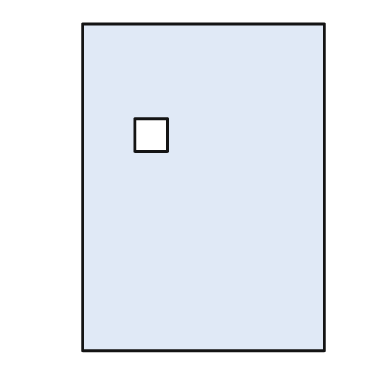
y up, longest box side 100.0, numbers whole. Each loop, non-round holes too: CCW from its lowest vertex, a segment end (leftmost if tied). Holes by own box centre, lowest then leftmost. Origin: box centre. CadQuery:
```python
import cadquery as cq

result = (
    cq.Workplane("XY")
    .moveTo(-37.0, -50.0)
    .lineTo(37.0, -50.0)
    .lineTo(37.0, 50.0)
    .lineTo(-37.0, 50.0)
    .close()
    .moveTo(-21.0, 11.0)
    .lineTo(-11.0, 11.0)
    .lineTo(-11.0, 21.0)
    .lineTo(-21.0, 21.0)
    .close()
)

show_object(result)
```